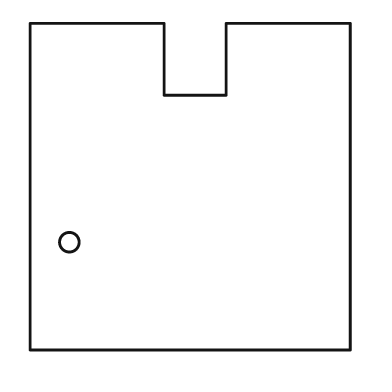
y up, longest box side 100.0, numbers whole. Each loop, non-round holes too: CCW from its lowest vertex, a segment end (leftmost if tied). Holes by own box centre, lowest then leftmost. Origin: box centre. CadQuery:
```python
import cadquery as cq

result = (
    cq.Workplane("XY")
    .moveTo(-49.0, -50.0)
    .lineTo(49.0, -50.0)
    .lineTo(49.0, 50.0)
    .lineTo(11.0, 50.0)
    .lineTo(11.0, 28.0)
    .lineTo(-8.0, 28.0)
    .lineTo(-8.0, 50.0)
    .lineTo(-49.0, 50.0)
    .close()
    .moveTo(-37.0, -17.0)
    .circle(3.0)
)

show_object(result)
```